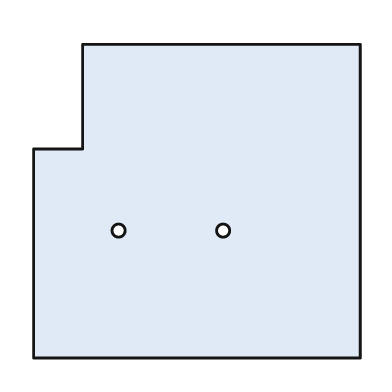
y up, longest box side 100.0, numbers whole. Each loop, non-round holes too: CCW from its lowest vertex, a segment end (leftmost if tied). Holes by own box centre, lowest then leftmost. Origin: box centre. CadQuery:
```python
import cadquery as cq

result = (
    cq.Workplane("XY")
    .moveTo(-50.0, -48.0)
    .lineTo(50.0, -48.0)
    .lineTo(50.0, 48.0)
    .lineTo(-35.0, 48.0)
    .lineTo(-35.0, 16.0)
    .lineTo(-50.0, 16.0)
    .close()
    .moveTo(-24.0, -9.0)
    .circle(2.0)
    .moveTo(8.0, -9.0)
    .circle(2.0)
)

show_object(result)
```